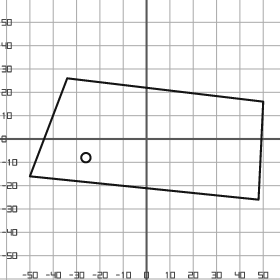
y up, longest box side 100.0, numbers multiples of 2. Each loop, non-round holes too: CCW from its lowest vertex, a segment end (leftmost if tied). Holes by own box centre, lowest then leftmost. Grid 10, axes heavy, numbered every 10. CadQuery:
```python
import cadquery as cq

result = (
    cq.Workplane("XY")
    .moveTo(48.0, -26.0)
    .lineTo(50.0, 16.0)
    .lineTo(-34.0, 26.0)
    .lineTo(-50.0, -16.0)
    .close()
    .moveTo(-26.0, -8.0)
    .circle(2.0)
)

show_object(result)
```